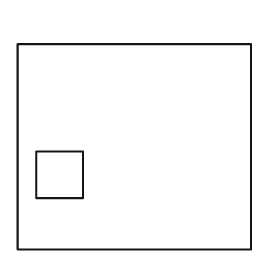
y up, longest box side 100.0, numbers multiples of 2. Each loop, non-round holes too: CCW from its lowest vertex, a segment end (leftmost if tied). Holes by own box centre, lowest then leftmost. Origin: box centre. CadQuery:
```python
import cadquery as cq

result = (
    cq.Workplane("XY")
    .moveTo(-50.0, -44.0)
    .lineTo(50.0, -44.0)
    .lineTo(50.0, 44.0)
    .lineTo(-50.0, 44.0)
    .close()
    .moveTo(-42.0, -22.0)
    .lineTo(-22.0, -22.0)
    .lineTo(-22.0, -2.0)
    .lineTo(-42.0, -2.0)
    .close()
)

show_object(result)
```